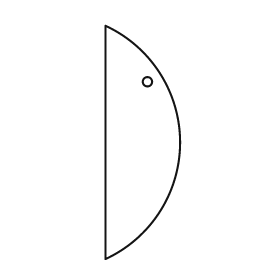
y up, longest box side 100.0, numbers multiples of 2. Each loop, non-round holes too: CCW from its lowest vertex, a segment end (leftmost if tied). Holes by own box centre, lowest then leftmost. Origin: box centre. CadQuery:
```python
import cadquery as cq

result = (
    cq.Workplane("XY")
    .moveTo(-16.0, -50.0)
    .threePointArc((16.0, 0.0), (-16.0, 50.0))
    .close()
    .moveTo(2.0, 26.0)
    .circle(2.0)
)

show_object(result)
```